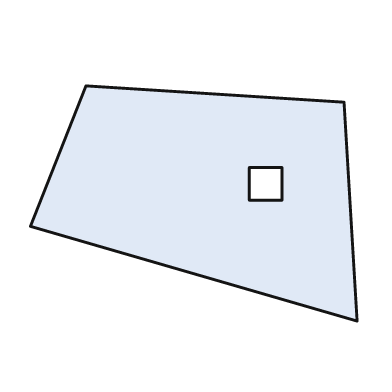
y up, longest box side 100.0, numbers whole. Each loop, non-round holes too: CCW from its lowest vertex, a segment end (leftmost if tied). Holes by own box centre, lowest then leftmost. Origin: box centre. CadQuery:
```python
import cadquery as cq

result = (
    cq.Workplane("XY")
    .moveTo(50.0, -36.0)
    .lineTo(46.0, 31.0)
    .lineTo(-33.0, 36.0)
    .lineTo(-50.0, -7.0)
    .close()
    .moveTo(17.0, 1.0)
    .lineTo(27.0, 1.0)
    .lineTo(27.0, 11.0)
    .lineTo(17.0, 11.0)
    .close()
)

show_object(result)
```